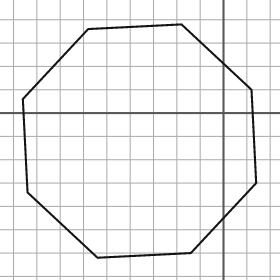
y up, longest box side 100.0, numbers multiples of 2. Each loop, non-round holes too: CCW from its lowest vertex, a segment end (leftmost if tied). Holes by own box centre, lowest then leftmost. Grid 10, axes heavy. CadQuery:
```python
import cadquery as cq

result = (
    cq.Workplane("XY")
    .moveTo(-54.0, -62.0)
    .lineTo(-14.0, -60.0)
    .lineTo(14.0, -30.0)
    .lineTo(12.0, 10.0)
    .lineTo(-18.0, 38.0)
    .lineTo(-58.0, 36.0)
    .lineTo(-86.0, 6.0)
    .lineTo(-84.0, -34.0)
    .close()
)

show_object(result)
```